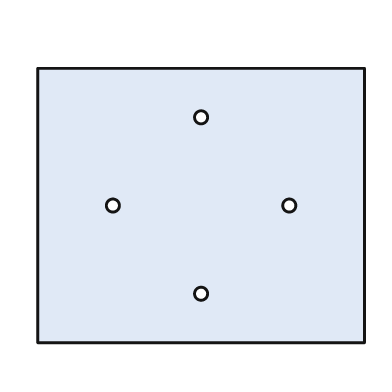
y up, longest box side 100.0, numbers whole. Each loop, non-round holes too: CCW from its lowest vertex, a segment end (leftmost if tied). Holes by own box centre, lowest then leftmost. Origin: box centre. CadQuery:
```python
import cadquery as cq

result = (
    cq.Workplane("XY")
    .moveTo(-50.0, -42.0)
    .lineTo(50.0, -42.0)
    .lineTo(50.0, 42.0)
    .lineTo(-50.0, 42.0)
    .close()
    .moveTo(0.0, -27.0)
    .circle(2.0)
    .moveTo(-27.0, 0.0)
    .circle(2.0)
    .moveTo(27.0, 0.0)
    .circle(2.0)
    .moveTo(0.0, 27.0)
    .circle(2.0)
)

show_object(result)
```